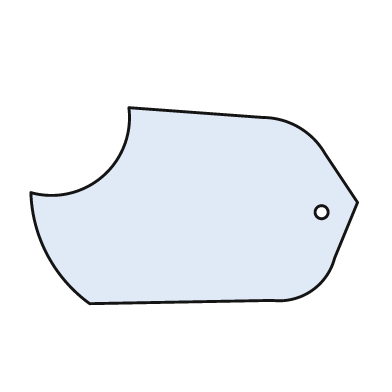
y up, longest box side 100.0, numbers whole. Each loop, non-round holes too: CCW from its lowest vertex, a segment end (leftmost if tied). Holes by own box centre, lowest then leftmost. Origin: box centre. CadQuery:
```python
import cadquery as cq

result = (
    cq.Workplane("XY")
    .moveTo(-32.0, -30.0)
    .lineTo(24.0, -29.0)
    .threePointArc((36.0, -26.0), (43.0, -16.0))
    .lineTo(50.0, 1.0)
    .lineTo(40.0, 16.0)
    .threePointArc((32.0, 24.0), (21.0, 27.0))
    .lineTo(-20.0, 30.0)
    .threePointArc((-28.0, 9.0), (-50.0, 4.0))
    .threePointArc((-45.0, -15.0), (-32.0, -30.0))
    .close()
    .moveTo(39.0, -2.0)
    .circle(2.0)
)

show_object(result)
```